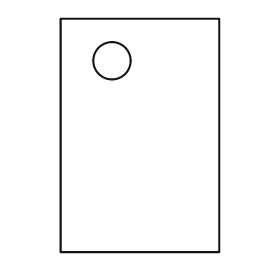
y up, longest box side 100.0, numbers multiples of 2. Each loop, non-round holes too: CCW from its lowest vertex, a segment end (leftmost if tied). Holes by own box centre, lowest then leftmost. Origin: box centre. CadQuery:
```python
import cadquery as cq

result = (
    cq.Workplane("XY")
    .moveTo(-34.0, -50.0)
    .lineTo(34.0, -50.0)
    .lineTo(34.0, 50.0)
    .lineTo(-34.0, 50.0)
    .close()
    .moveTo(-12.0, 32.0)
    .circle(8.0)
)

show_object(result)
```